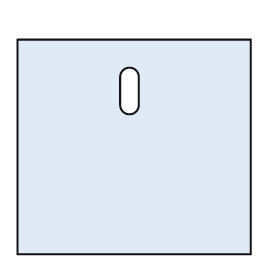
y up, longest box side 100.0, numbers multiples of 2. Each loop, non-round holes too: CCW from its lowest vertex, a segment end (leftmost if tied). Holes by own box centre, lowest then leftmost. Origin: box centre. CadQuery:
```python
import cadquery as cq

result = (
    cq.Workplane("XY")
    .moveTo(-50.0, -46.0)
    .lineTo(50.0, -46.0)
    .lineTo(50.0, 46.0)
    .lineTo(-50.0, 46.0)
    .close()
    .moveTo(-6.0, 18.0)
    .threePointArc((-2.0, 14.0), (2.0, 18.0))
    .lineTo(2.0, 30.0)
    .threePointArc((-2.0, 34.0), (-6.0, 30.0))
    .close()
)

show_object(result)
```